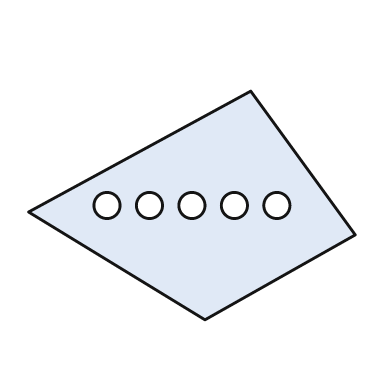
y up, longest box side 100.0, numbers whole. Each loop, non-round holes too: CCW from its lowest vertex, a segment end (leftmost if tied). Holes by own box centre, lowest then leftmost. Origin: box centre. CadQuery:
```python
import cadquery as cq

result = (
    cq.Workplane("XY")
    .moveTo(4.0, -35.0)
    .lineTo(50.0, -9.0)
    .lineTo(18.0, 35.0)
    .lineTo(-50.0, -2.0)
    .close()
    .moveTo(-26.0, 0.0)
    .circle(4.0)
    .moveTo(-13.0, 0.0)
    .circle(4.0)
    .moveTo(0.0, 0.0)
    .circle(4.0)
    .moveTo(13.0, 0.0)
    .circle(4.0)
    .moveTo(26.0, 0.0)
    .circle(4.0)
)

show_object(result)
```